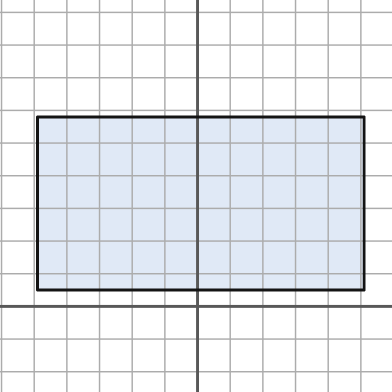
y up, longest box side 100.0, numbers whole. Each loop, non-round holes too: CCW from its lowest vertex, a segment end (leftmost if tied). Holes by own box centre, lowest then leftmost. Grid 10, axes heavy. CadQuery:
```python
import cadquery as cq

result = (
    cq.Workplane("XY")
    .moveTo(-49.0, 5.0)
    .lineTo(51.0, 5.0)
    .lineTo(51.0, 58.0)
    .lineTo(-49.0, 58.0)
    .close()
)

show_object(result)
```